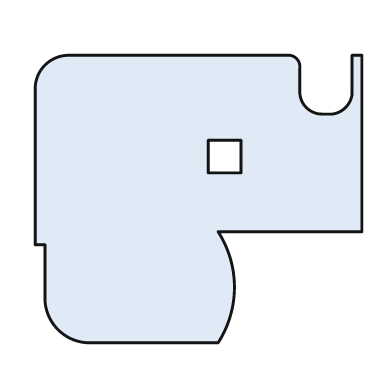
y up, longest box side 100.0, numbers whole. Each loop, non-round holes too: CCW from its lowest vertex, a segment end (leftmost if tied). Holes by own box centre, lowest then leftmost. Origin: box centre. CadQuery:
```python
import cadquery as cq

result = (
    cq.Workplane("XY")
    .moveTo(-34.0, -44.0)
    .lineTo(6.0, -44.0)
    .threePointArc((11.0, -27.0), (6.0, -10.0))
    .lineTo(50.0, -10.0)
    .lineTo(50.0, 44.0)
    .lineTo(47.0, 44.0)
    .lineTo(47.0, 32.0)
    .threePointArc((45.0, 28.0), (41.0, 26.0))
    .lineTo(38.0, 26.0)
    .threePointArc((33.0, 28.0), (31.0, 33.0))
    .lineTo(31.0, 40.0)
    .threePointArc((30.0, 43.0), (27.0, 44.0))
    .lineTo(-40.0, 44.0)
    .threePointArc((-47.0, 41.0), (-50.0, 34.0))
    .lineTo(-50.0, -14.0)
    .lineTo(-47.0, -14.0)
    .lineTo(-47.0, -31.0)
    .threePointArc((-43.0, -40.0), (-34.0, -44.0))
    .close()
    .moveTo(3.0, 8.0)
    .lineTo(13.0, 8.0)
    .lineTo(13.0, 18.0)
    .lineTo(3.0, 18.0)
    .close()
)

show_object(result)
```